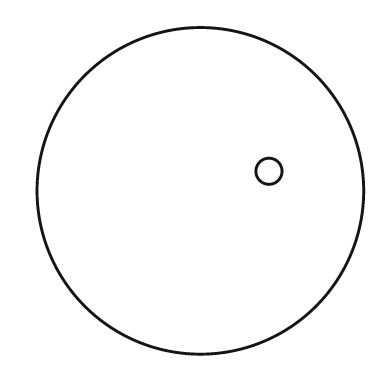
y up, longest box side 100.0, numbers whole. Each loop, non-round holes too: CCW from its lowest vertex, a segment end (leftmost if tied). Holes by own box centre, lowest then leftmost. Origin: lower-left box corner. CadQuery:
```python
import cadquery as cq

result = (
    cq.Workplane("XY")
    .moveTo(50.0, 50.0)
    .circle(50.0)
    .moveTo(71.0, 56.0)
    .circle(4.0)
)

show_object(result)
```